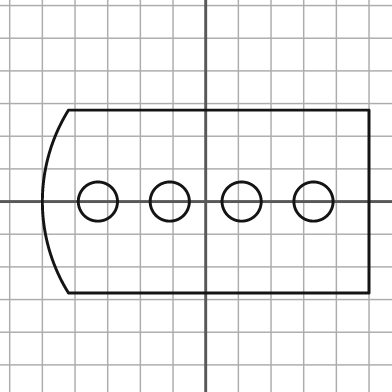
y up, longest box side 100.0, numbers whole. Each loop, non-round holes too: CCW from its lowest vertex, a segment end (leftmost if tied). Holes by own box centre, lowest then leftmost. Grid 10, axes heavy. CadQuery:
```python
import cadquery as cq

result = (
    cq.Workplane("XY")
    .moveTo(-42.0, -28.0)
    .lineTo(50.0, -28.0)
    .lineTo(50.0, 28.0)
    .lineTo(-42.0, 28.0)
    .threePointArc((-50.0, 0.0), (-42.0, -28.0))
    .close()
    .moveTo(-33.0, 0.0)
    .circle(6.0)
    .moveTo(-11.0, 0.0)
    .circle(6.0)
    .moveTo(11.0, 0.0)
    .circle(6.0)
    .moveTo(33.0, 0.0)
    .circle(6.0)
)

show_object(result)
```